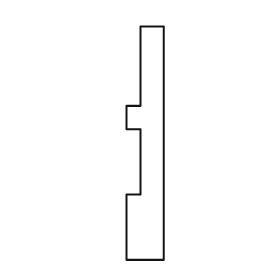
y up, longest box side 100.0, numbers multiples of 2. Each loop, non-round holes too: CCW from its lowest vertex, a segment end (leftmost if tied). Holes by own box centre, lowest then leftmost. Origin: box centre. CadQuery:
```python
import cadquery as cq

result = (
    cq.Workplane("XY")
    .moveTo(-8.0, -50.0)
    .lineTo(8.0, -50.0)
    .lineTo(8.0, 50.0)
    .lineTo(-2.0, 50.0)
    .lineTo(-2.0, 16.0)
    .lineTo(-8.0, 16.0)
    .lineTo(-8.0, 6.0)
    .lineTo(-2.0, 6.0)
    .lineTo(-2.0, -22.0)
    .lineTo(-8.0, -22.0)
    .close()
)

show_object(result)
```